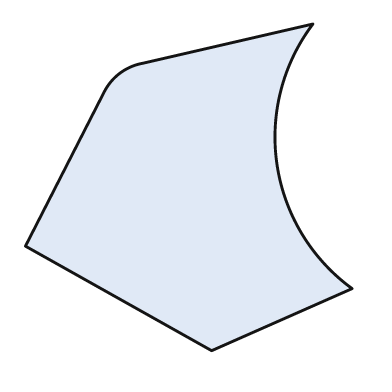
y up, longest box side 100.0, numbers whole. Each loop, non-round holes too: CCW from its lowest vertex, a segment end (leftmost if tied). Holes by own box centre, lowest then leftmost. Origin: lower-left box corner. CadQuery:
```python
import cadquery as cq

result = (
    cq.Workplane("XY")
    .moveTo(57.0, 0.0)
    .lineTo(100.0, 19.0)
    .threePointArc((77.0, 57.0), (88.0, 100.0))
    .lineTo(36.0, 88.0)
    .threePointArc((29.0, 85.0), (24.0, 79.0))
    .lineTo(0.0, 32.0)
    .close()
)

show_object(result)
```